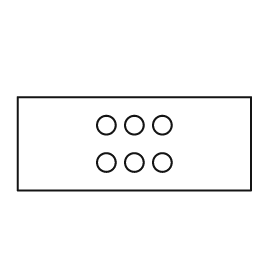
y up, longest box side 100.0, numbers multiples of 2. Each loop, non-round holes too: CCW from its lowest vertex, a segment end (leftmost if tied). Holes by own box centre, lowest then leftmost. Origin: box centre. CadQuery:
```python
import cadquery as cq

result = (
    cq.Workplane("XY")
    .moveTo(-50.0, -20.0)
    .lineTo(50.0, -20.0)
    .lineTo(50.0, 20.0)
    .lineTo(-50.0, 20.0)
    .close()
    .moveTo(-12.0, -8.0)
    .circle(4.0)
    .moveTo(0.0, -8.0)
    .circle(4.0)
    .moveTo(12.0, -8.0)
    .circle(4.0)
    .moveTo(-12.0, 8.0)
    .circle(4.0)
    .moveTo(0.0, 8.0)
    .circle(4.0)
    .moveTo(12.0, 8.0)
    .circle(4.0)
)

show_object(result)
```